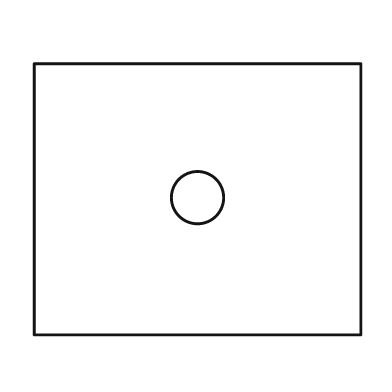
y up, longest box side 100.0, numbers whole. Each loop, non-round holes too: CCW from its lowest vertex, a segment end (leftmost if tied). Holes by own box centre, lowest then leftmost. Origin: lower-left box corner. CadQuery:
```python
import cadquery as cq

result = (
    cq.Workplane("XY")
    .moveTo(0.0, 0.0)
    .lineTo(100.0, 0.0)
    .lineTo(100.0, 83.0)
    .lineTo(0.0, 83.0)
    .close()
    .moveTo(50.0, 42.0)
    .circle(8.0)
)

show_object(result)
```